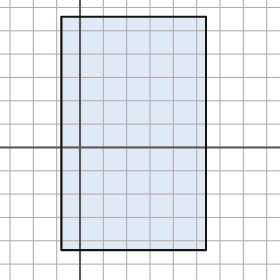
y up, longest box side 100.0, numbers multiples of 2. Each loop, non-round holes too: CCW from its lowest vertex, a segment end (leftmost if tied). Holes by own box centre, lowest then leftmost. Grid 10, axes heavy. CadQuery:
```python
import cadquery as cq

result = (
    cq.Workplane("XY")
    .moveTo(-8.0, -44.0)
    .lineTo(54.0, -44.0)
    .lineTo(54.0, 56.0)
    .lineTo(-8.0, 56.0)
    .close()
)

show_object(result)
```